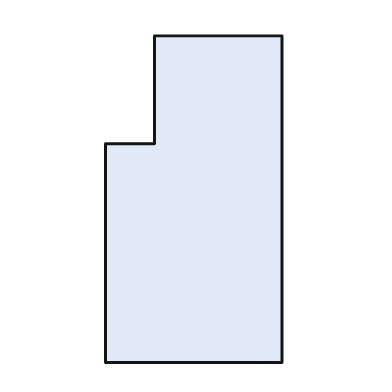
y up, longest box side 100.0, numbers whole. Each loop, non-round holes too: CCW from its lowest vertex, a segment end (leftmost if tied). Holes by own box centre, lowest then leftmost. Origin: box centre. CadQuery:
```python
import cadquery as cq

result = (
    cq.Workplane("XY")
    .moveTo(-27.0, -50.0)
    .lineTo(27.0, -50.0)
    .lineTo(27.0, 50.0)
    .lineTo(-12.0, 50.0)
    .lineTo(-12.0, 17.0)
    .lineTo(-27.0, 17.0)
    .close()
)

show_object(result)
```